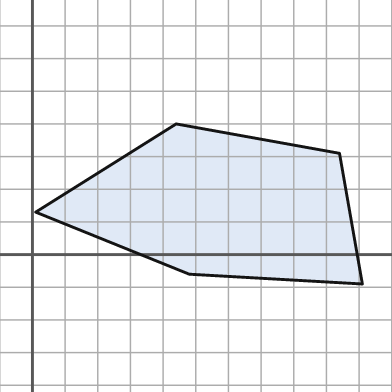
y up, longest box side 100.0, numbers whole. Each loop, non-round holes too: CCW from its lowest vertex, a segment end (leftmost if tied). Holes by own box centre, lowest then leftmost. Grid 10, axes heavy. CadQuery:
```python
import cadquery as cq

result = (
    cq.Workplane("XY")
    .moveTo(101.0, -9.0)
    .lineTo(94.0, 31.0)
    .lineTo(44.0, 40.0)
    .lineTo(1.0, 13.0)
    .lineTo(48.0, -6.0)
    .close()
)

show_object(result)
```